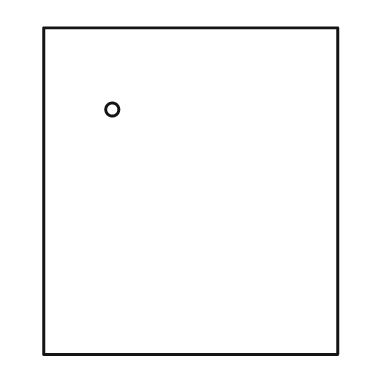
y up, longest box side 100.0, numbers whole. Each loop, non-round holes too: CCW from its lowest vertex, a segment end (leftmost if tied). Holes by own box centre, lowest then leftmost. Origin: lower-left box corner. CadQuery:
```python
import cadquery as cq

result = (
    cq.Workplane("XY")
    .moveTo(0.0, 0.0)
    .lineTo(90.0, 0.0)
    .lineTo(90.0, 100.0)
    .lineTo(0.0, 100.0)
    .close()
    .moveTo(21.0, 75.0)
    .circle(2.0)
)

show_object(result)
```